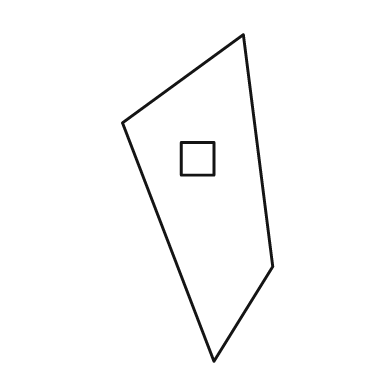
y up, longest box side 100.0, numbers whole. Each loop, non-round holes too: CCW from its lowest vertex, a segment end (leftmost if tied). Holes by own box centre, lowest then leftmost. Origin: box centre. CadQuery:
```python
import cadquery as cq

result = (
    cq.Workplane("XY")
    .moveTo(5.0, -50.0)
    .lineTo(23.0, -21.0)
    .lineTo(14.0, 50.0)
    .lineTo(-23.0, 23.0)
    .close()
    .moveTo(-5.0, 7.0)
    .lineTo(5.0, 7.0)
    .lineTo(5.0, 17.0)
    .lineTo(-5.0, 17.0)
    .close()
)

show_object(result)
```